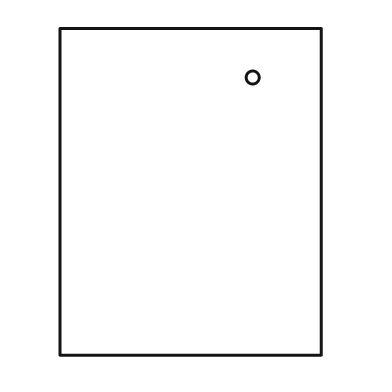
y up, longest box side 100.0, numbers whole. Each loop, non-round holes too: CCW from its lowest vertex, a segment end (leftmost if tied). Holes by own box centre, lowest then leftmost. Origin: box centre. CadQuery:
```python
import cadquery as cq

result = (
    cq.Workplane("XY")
    .moveTo(-40.0, -50.0)
    .lineTo(40.0, -50.0)
    .lineTo(40.0, 50.0)
    .lineTo(-40.0, 50.0)
    .close()
    .moveTo(19.0, 35.0)
    .circle(2.0)
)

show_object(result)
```